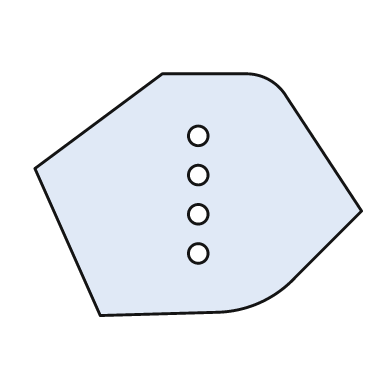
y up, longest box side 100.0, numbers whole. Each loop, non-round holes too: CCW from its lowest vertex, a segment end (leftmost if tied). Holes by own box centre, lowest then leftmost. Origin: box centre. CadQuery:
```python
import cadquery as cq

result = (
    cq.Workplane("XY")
    .moveTo(-30.0, -37.0)
    .lineTo(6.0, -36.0)
    .threePointArc((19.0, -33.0), (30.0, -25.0))
    .lineTo(50.0, -5.0)
    .lineTo(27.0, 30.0)
    .threePointArc((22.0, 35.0), (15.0, 37.0))
    .lineTo(-11.0, 37.0)
    .lineTo(-50.0, 8.0)
    .close()
    .moveTo(0.0, -18.0)
    .circle(3.0)
    .moveTo(0.0, -6.0)
    .circle(3.0)
    .moveTo(0.0, 6.0)
    .circle(3.0)
    .moveTo(0.0, 18.0)
    .circle(3.0)
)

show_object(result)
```